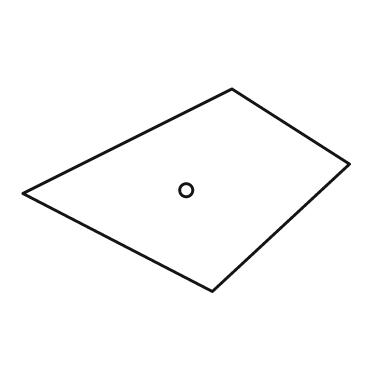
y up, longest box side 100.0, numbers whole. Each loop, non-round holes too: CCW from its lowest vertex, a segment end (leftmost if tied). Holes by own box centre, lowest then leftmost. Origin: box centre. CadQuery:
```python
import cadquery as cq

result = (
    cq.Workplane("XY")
    .moveTo(8.0, -31.0)
    .lineTo(50.0, 8.0)
    .lineTo(14.0, 31.0)
    .lineTo(-50.0, -1.0)
    .close()
    .moveTo(0.0, 0.0)
    .circle(2.0)
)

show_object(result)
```